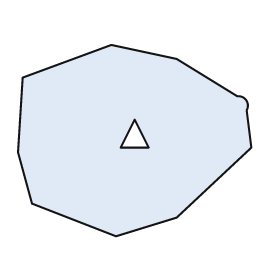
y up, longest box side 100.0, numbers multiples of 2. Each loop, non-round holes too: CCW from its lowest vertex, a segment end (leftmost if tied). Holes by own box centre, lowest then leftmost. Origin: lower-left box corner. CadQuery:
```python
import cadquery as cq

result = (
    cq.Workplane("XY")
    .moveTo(42.0, 0.0)
    .lineTo(68.0, 8.0)
    .lineTo(100.0, 38.0)
    .lineTo(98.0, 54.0)
    .threePointArc((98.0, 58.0), (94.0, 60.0))
    .lineTo(68.0, 76.0)
    .lineTo(40.0, 82.0)
    .lineTo(2.0, 68.0)
    .lineTo(0.0, 36.0)
    .lineTo(6.0, 14.0)
    .close()
    .moveTo(44.0, 38.0)
    .lineTo(56.0, 38.0)
    .lineTo(50.0, 50.0)
    .close()
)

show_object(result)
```